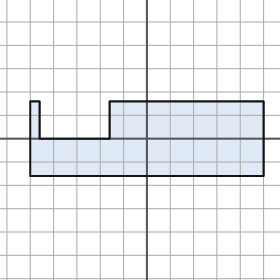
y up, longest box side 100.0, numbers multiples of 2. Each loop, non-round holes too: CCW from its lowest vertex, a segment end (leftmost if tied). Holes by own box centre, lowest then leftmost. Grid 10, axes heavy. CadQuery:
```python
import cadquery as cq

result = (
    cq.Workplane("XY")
    .moveTo(-50.0, -16.0)
    .lineTo(50.0, -16.0)
    .lineTo(50.0, 16.0)
    .lineTo(-16.0, 16.0)
    .lineTo(-16.0, 0.0)
    .lineTo(-46.0, 0.0)
    .lineTo(-46.0, 16.0)
    .lineTo(-50.0, 16.0)
    .close()
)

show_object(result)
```